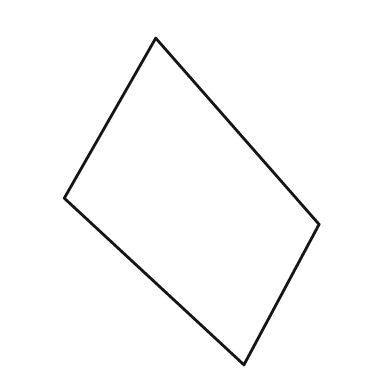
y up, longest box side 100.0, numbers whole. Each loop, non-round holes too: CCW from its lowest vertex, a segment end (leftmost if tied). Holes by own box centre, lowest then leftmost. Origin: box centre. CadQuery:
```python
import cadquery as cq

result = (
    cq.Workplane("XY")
    .moveTo(16.0, -50.0)
    .lineTo(39.0, -7.0)
    .lineTo(-11.0, 50.0)
    .lineTo(-39.0, 1.0)
    .close()
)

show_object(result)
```